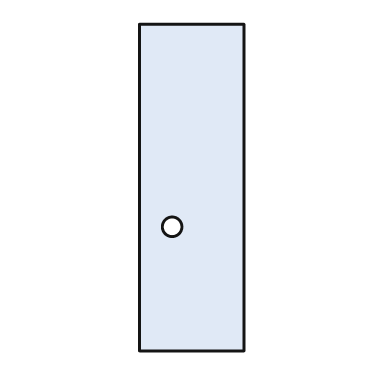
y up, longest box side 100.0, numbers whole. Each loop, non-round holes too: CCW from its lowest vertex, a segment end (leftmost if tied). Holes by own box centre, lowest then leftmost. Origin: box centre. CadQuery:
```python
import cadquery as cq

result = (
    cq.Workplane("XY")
    .moveTo(-16.0, -50.0)
    .lineTo(16.0, -50.0)
    .lineTo(16.0, 50.0)
    .lineTo(-16.0, 50.0)
    .close()
    .moveTo(-6.0, -12.0)
    .circle(3.0)
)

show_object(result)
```